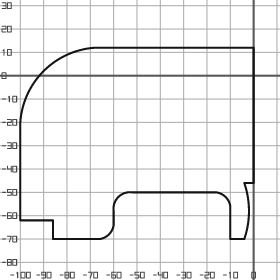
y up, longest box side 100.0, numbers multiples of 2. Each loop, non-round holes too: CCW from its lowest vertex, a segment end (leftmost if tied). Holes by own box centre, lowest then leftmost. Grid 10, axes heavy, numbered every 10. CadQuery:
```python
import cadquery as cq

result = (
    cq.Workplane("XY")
    .moveTo(-86.0, -70.0)
    .lineTo(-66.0, -70.0)
    .threePointArc((-62.0, -68.0), (-60.0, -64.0))
    .lineTo(-60.0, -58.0)
    .threePointArc((-58.0, -52.0), (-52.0, -50.0))
    .lineTo(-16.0, -50.0)
    .threePointArc((-12.0, -52.0), (-10.0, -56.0))
    .lineTo(-10.0, -70.0)
    .lineTo(-4.0, -70.0)
    .threePointArc((-2.0, -58.0), (-4.0, -46.0))
    .lineTo(0.0, -46.0)
    .lineTo(0.0, 12.0)
    .lineTo(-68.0, 12.0)
    .threePointArc((-90.0, 2.0), (-100.0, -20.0))
    .lineTo(-100.0, -62.0)
    .lineTo(-86.0, -62.0)
    .close()
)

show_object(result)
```